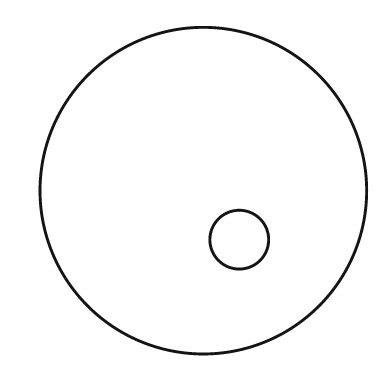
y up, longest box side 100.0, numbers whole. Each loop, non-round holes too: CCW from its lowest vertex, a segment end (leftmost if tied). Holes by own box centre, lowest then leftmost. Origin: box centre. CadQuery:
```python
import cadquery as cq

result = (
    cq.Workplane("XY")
    .moveTo(0.0, 0.0)
    .circle(50.0)
    .moveTo(11.0, -15.0)
    .circle(9.0)
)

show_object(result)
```